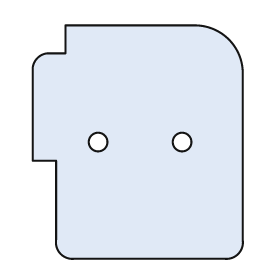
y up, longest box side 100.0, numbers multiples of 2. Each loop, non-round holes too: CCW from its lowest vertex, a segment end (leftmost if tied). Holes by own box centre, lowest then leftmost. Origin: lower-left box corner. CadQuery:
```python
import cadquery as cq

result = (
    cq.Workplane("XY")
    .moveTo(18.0, 0.0)
    .lineTo(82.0, 0.0)
    .threePointArc((88.0, 2.0), (90.0, 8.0))
    .lineTo(90.0, 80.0)
    .threePointArc((84.0, 94.0), (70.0, 100.0))
    .lineTo(14.0, 100.0)
    .lineTo(14.0, 88.0)
    .lineTo(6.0, 88.0)
    .threePointArc((2.0, 86.0), (0.0, 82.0))
    .lineTo(0.0, 42.0)
    .lineTo(10.0, 42.0)
    .lineTo(10.0, 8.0)
    .threePointArc((12.0, 2.0), (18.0, 0.0))
    .close()
    .moveTo(28.0, 50.0)
    .circle(4.0)
    .moveTo(64.0, 50.0)
    .circle(4.0)
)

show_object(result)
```